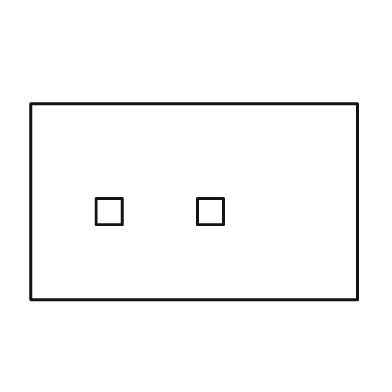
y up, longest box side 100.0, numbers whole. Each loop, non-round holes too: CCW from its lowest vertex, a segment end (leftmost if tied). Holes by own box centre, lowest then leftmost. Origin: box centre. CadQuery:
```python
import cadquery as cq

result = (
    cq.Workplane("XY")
    .moveTo(-50.0, -30.0)
    .lineTo(50.0, -30.0)
    .lineTo(50.0, 30.0)
    .lineTo(-50.0, 30.0)
    .close()
    .moveTo(-30.0, -7.0)
    .lineTo(-22.0, -7.0)
    .lineTo(-22.0, 1.0)
    .lineTo(-30.0, 1.0)
    .close()
    .moveTo(1.0, -7.0)
    .lineTo(9.0, -7.0)
    .lineTo(9.0, 1.0)
    .lineTo(1.0, 1.0)
    .close()
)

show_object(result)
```